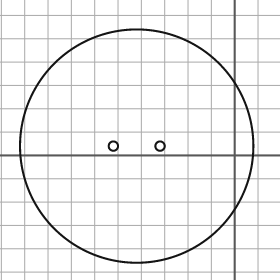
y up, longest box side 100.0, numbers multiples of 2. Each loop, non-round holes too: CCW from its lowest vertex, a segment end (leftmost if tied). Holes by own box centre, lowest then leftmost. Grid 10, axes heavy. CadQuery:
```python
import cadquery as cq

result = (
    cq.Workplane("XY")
    .moveTo(-42.0, 4.0)
    .circle(50.0)
    .moveTo(-52.0, 4.0)
    .circle(2.0)
    .moveTo(-32.0, 4.0)
    .circle(2.0)
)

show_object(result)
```